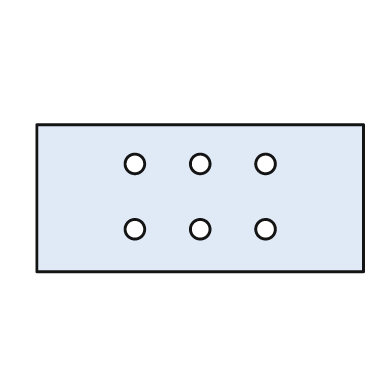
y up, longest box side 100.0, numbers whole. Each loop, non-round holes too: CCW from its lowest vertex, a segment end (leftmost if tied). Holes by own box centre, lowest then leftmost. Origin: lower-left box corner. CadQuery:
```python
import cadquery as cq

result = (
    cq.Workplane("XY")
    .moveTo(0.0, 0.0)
    .lineTo(100.0, 0.0)
    .lineTo(100.0, 45.0)
    .lineTo(0.0, 45.0)
    .close()
    .moveTo(30.0, 13.0)
    .circle(3.0)
    .moveTo(50.0, 13.0)
    .circle(3.0)
    .moveTo(70.0, 13.0)
    .circle(3.0)
    .moveTo(30.0, 33.0)
    .circle(3.0)
    .moveTo(50.0, 33.0)
    .circle(3.0)
    .moveTo(70.0, 33.0)
    .circle(3.0)
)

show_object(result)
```